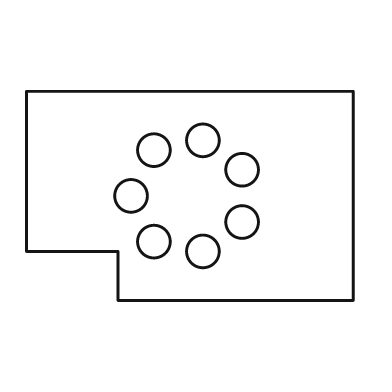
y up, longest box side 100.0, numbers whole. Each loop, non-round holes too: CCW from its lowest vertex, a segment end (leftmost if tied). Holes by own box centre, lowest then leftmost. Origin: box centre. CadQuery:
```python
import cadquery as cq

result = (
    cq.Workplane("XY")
    .moveTo(-22.0, -32.0)
    .lineTo(50.0, -32.0)
    .lineTo(50.0, 32.0)
    .lineTo(-50.0, 32.0)
    .lineTo(-50.0, -17.0)
    .lineTo(-22.0, -17.0)
    .close()
    .moveTo(4.0, -17.0)
    .circle(5.0)
    .moveTo(-11.0, -14.0)
    .circle(5.0)
    .moveTo(16.0, -8.0)
    .circle(5.0)
    .moveTo(-18.0, 0.0)
    .circle(5.0)
    .moveTo(16.0, 8.0)
    .circle(5.0)
    .moveTo(-11.0, 14.0)
    .circle(5.0)
    .moveTo(4.0, 17.0)
    .circle(5.0)
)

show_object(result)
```